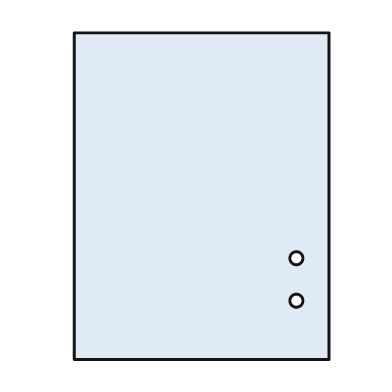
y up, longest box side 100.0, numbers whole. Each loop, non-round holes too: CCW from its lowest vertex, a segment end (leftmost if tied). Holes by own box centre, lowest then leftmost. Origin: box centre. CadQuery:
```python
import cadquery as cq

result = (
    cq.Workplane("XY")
    .moveTo(-39.0, -50.0)
    .lineTo(39.0, -50.0)
    .lineTo(39.0, 50.0)
    .lineTo(-39.0, 50.0)
    .close()
    .moveTo(29.0, -32.0)
    .circle(2.0)
    .moveTo(29.0, -19.0)
    .circle(2.0)
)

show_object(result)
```